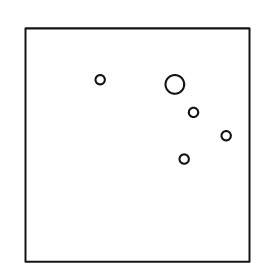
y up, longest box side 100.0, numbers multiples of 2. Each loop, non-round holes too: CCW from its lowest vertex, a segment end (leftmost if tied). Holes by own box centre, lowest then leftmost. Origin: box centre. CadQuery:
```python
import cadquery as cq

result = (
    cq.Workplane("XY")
    .moveTo(-48.0, -50.0)
    .lineTo(48.0, -50.0)
    .lineTo(48.0, 50.0)
    .lineTo(-48.0, 50.0)
    .close()
    .moveTo(20.0, -6.0)
    .circle(2.0)
    .moveTo(38.0, 4.0)
    .circle(2.0)
    .moveTo(24.0, 14.0)
    .circle(2.0)
    .moveTo(16.0, 26.0)
    .circle(4.0)
    .moveTo(-16.0, 28.0)
    .circle(2.0)
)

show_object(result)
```